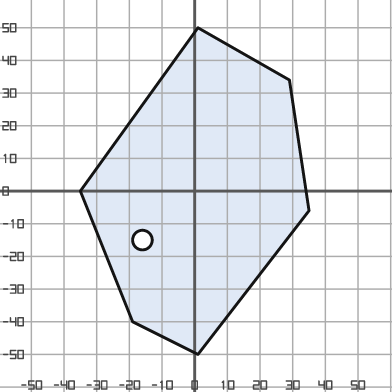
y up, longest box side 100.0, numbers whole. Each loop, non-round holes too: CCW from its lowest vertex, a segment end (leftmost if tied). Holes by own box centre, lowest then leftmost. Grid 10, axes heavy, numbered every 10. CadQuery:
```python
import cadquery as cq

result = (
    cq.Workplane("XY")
    .moveTo(1.0, -50.0)
    .lineTo(35.0, -6.0)
    .lineTo(29.0, 34.0)
    .lineTo(1.0, 50.0)
    .lineTo(-35.0, 0.0)
    .lineTo(-19.0, -40.0)
    .close()
    .moveTo(-16.0, -15.0)
    .circle(3.0)
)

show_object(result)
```